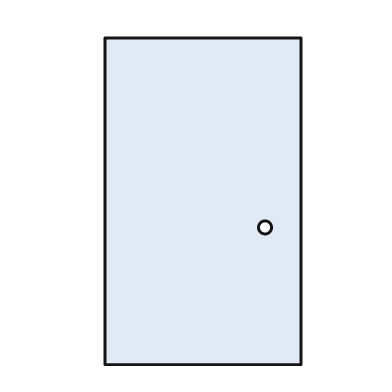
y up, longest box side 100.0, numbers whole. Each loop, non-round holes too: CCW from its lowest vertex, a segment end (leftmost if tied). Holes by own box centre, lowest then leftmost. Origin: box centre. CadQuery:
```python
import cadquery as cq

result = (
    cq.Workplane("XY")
    .moveTo(-30.0, -50.0)
    .lineTo(30.0, -50.0)
    .lineTo(30.0, 50.0)
    .lineTo(-30.0, 50.0)
    .close()
    .moveTo(19.0, -8.0)
    .circle(2.0)
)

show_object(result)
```